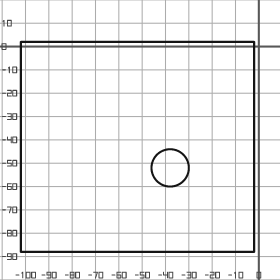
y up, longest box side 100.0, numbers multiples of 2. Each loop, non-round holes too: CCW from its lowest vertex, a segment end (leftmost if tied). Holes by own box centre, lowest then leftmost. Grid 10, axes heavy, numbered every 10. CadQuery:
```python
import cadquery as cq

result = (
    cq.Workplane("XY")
    .moveTo(-102.0, -88.0)
    .lineTo(-2.0, -88.0)
    .lineTo(-2.0, 2.0)
    .lineTo(-102.0, 2.0)
    .close()
    .moveTo(-38.0, -52.0)
    .circle(8.0)
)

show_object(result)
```